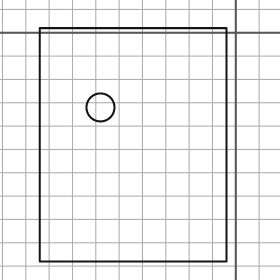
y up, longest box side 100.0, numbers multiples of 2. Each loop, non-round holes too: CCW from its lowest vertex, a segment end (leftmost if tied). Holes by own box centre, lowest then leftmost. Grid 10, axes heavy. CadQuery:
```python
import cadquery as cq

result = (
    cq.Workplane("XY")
    .moveTo(-84.0, -98.0)
    .lineTo(-4.0, -98.0)
    .lineTo(-4.0, 2.0)
    .lineTo(-84.0, 2.0)
    .close()
    .moveTo(-58.0, -32.0)
    .circle(6.0)
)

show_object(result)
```